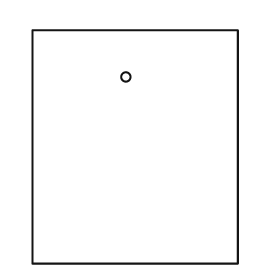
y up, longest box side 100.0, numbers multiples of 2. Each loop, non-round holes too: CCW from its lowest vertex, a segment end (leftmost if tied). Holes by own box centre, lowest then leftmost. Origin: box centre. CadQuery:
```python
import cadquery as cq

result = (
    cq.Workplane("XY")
    .moveTo(-44.0, -50.0)
    .lineTo(44.0, -50.0)
    .lineTo(44.0, 50.0)
    .lineTo(-44.0, 50.0)
    .close()
    .moveTo(-4.0, 30.0)
    .circle(2.0)
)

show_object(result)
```